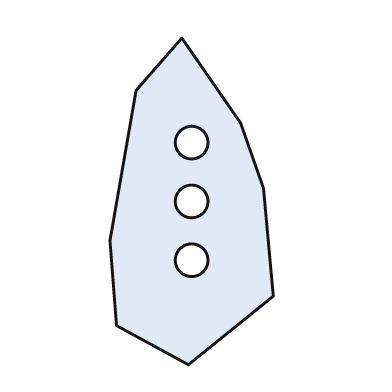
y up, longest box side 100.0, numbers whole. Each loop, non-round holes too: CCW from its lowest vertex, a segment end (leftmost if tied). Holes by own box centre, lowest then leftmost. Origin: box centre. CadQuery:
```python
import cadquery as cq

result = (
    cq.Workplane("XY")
    .moveTo(-1.0, -50.0)
    .lineTo(25.0, -29.0)
    .lineTo(22.0, 4.0)
    .lineTo(15.0, 24.0)
    .lineTo(-3.0, 50.0)
    .lineTo(-17.0, 34.0)
    .lineTo(-25.0, -12.0)
    .lineTo(-23.0, -38.0)
    .close()
    .moveTo(0.0, -18.0)
    .circle(5.0)
    .moveTo(0.0, 0.0)
    .circle(5.0)
    .moveTo(0.0, 18.0)
    .circle(5.0)
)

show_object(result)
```